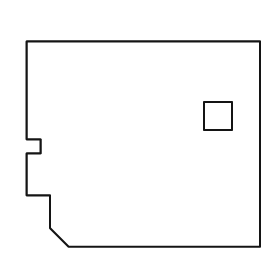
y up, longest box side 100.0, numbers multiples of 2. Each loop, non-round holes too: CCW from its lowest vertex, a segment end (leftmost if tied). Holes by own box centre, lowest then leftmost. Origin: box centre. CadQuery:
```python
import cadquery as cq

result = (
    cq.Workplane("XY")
    .moveTo(-32.0, -44.0)
    .lineTo(50.0, -44.0)
    .lineTo(50.0, 44.0)
    .lineTo(-50.0, 44.0)
    .lineTo(-50.0, 2.0)
    .lineTo(-44.0, 2.0)
    .lineTo(-44.0, -4.0)
    .lineTo(-50.0, -4.0)
    .lineTo(-50.0, -22.0)
    .lineTo(-40.0, -22.0)
    .lineTo(-40.0, -36.0)
    .close()
    .moveTo(26.0, 6.0)
    .lineTo(38.0, 6.0)
    .lineTo(38.0, 18.0)
    .lineTo(26.0, 18.0)
    .close()
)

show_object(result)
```